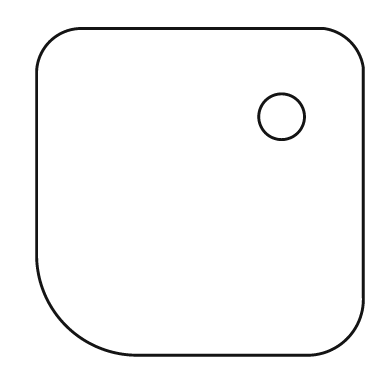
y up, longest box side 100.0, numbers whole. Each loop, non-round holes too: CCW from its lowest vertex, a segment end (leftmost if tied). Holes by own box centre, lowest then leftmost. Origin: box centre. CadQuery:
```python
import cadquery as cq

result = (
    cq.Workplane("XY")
    .moveTo(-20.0, -50.0)
    .lineTo(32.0, -50.0)
    .threePointArc((45.0, -45.0), (50.0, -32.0))
    .lineTo(50.0, 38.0)
    .threePointArc((46.0, 46.0), (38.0, 50.0))
    .lineTo(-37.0, 50.0)
    .threePointArc((-46.0, 46.0), (-50.0, 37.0))
    .lineTo(-50.0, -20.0)
    .threePointArc((-41.0, -41.0), (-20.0, -50.0))
    .close()
    .moveTo(25.0, 23.0)
    .circle(7.0)
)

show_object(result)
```